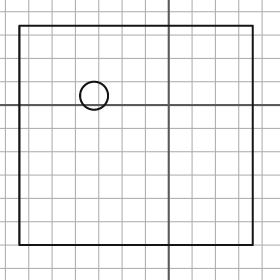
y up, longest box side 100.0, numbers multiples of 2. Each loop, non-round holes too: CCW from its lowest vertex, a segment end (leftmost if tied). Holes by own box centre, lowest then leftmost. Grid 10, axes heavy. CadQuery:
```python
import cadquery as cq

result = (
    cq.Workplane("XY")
    .moveTo(-64.0, -60.0)
    .lineTo(36.0, -60.0)
    .lineTo(36.0, 34.0)
    .lineTo(-64.0, 34.0)
    .close()
    .moveTo(-32.0, 4.0)
    .circle(6.0)
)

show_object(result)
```